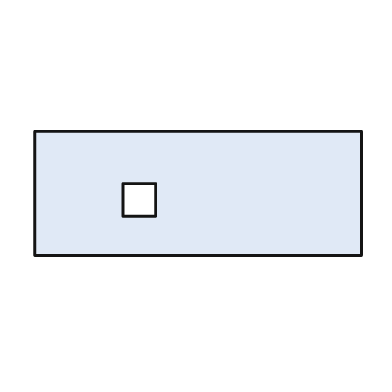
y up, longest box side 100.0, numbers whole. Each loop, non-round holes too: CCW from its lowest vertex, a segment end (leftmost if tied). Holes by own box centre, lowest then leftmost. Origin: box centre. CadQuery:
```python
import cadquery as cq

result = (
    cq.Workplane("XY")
    .moveTo(-50.0, -19.0)
    .lineTo(50.0, -19.0)
    .lineTo(50.0, 19.0)
    .lineTo(-50.0, 19.0)
    .close()
    .moveTo(-23.0, -7.0)
    .lineTo(-13.0, -7.0)
    .lineTo(-13.0, 3.0)
    .lineTo(-23.0, 3.0)
    .close()
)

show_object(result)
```